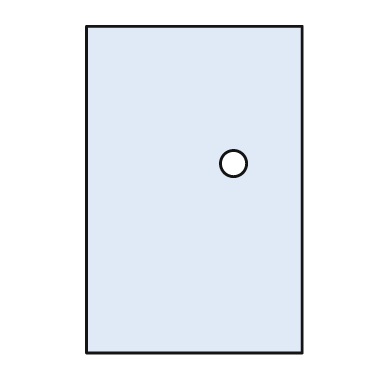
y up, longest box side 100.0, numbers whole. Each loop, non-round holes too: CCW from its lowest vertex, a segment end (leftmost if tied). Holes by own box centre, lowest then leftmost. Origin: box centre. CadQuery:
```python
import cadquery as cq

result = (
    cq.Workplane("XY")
    .moveTo(-33.0, -50.0)
    .lineTo(33.0, -50.0)
    .lineTo(33.0, 50.0)
    .lineTo(-33.0, 50.0)
    .close()
    .moveTo(12.0, 8.0)
    .circle(4.0)
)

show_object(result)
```